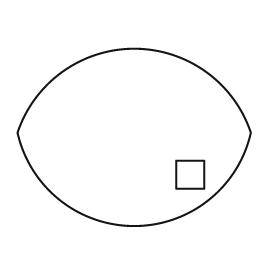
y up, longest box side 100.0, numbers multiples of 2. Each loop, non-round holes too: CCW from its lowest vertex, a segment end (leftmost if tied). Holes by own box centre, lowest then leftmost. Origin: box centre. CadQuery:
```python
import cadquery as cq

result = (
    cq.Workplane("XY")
    .moveTo(-50.0, 2.0)
    .threePointArc((0.0, -38.0), (50.0, 2.0))
    .threePointArc((0.0, 38.0), (-50.0, 2.0))
    .close()
    .moveTo(18.0, -22.0)
    .lineTo(30.0, -22.0)
    .lineTo(30.0, -10.0)
    .lineTo(18.0, -10.0)
    .close()
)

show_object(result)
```